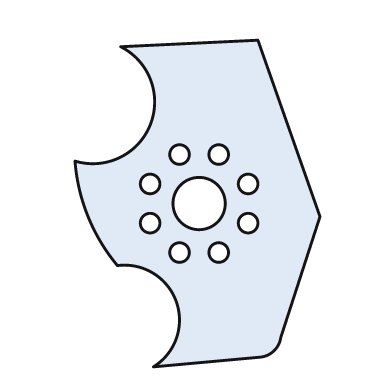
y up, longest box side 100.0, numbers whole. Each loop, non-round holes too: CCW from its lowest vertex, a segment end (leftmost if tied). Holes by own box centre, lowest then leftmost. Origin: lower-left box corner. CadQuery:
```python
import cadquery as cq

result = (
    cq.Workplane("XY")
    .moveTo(24.0, 0.0)
    .lineTo(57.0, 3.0)
    .threePointArc((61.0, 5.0), (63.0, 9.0))
    .lineTo(75.0, 46.0)
    .lineTo(56.0, 100.0)
    .lineTo(14.0, 98.0)
    .threePointArc((23.0, 74.0), (0.0, 63.0))
    .threePointArc((4.0, 46.0), (13.0, 31.0))
    .threePointArc((31.0, 20.0), (24.0, 0.0))
    .close()
    .moveTo(32.0, 35.0)
    .circle(3.0)
    .moveTo(44.0, 35.0)
    .circle(3.0)
    .moveTo(23.0, 44.0)
    .circle(3.0)
    .moveTo(53.0, 44.0)
    .circle(3.0)
    .moveTo(38.0, 50.0)
    .circle(8.0)
    .moveTo(23.0, 56.0)
    .circle(3.0)
    .moveTo(53.0, 56.0)
    .circle(3.0)
    .moveTo(32.0, 65.0)
    .circle(3.0)
    .moveTo(44.0, 65.0)
    .circle(3.0)
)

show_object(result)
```